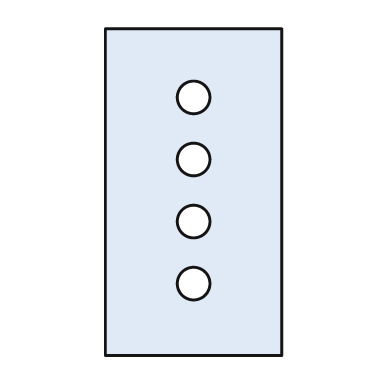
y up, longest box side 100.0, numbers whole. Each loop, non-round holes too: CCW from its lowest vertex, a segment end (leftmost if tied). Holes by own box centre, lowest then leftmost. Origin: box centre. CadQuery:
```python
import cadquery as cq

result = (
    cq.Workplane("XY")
    .moveTo(-27.0, -50.0)
    .lineTo(27.0, -50.0)
    .lineTo(27.0, 50.0)
    .lineTo(-27.0, 50.0)
    .close()
    .moveTo(0.0, -28.0)
    .circle(5.0)
    .moveTo(0.0, -9.0)
    .circle(5.0)
    .moveTo(0.0, 10.0)
    .circle(5.0)
    .moveTo(0.0, 29.0)
    .circle(5.0)
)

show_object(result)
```